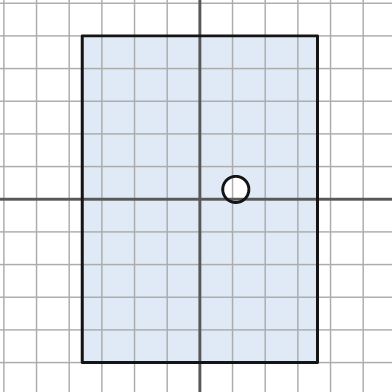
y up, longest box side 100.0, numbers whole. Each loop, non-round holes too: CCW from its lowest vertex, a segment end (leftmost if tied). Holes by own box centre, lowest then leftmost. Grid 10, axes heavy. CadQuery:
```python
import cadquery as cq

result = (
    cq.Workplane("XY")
    .moveTo(-36.0, -50.0)
    .lineTo(36.0, -50.0)
    .lineTo(36.0, 50.0)
    .lineTo(-36.0, 50.0)
    .close()
    .moveTo(11.0, 3.0)
    .circle(4.0)
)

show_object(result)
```